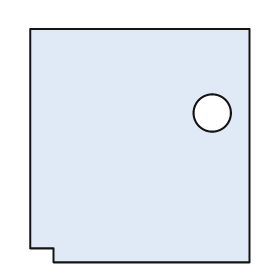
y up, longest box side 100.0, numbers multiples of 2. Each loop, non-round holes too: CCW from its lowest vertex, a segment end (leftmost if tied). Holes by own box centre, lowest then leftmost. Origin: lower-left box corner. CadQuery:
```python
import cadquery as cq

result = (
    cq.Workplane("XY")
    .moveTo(10.0, 0.0)
    .lineTo(94.0, 0.0)
    .lineTo(94.0, 100.0)
    .lineTo(0.0, 100.0)
    .lineTo(0.0, 6.0)
    .lineTo(10.0, 6.0)
    .close()
    .moveTo(78.0, 64.0)
    .circle(8.0)
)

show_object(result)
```